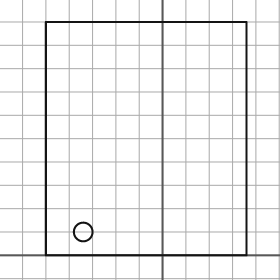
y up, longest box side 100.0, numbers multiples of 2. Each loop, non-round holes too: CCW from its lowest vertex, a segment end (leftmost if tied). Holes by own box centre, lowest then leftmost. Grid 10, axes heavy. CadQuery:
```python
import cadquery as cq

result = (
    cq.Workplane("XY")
    .moveTo(-50.0, 0.0)
    .lineTo(36.0, 0.0)
    .lineTo(36.0, 100.0)
    .lineTo(-50.0, 100.0)
    .close()
    .moveTo(-34.0, 10.0)
    .circle(4.0)
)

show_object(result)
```